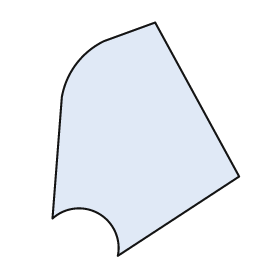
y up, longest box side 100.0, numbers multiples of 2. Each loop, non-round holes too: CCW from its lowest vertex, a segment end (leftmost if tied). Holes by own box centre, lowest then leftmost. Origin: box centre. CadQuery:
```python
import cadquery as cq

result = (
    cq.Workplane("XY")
    .moveTo(-12.0, -50.0)
    .lineTo(40.0, -16.0)
    .lineTo(4.0, 50.0)
    .lineTo(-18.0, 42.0)
    .threePointArc((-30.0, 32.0), (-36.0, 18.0))
    .lineTo(-40.0, -34.0)
    .threePointArc((-20.0, -32.0), (-12.0, -50.0))
    .close()
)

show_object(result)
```